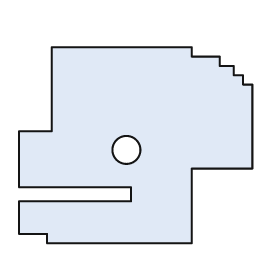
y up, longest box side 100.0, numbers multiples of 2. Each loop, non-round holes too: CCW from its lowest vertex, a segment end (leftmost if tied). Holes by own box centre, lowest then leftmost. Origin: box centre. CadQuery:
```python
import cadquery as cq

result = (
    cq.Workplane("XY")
    .moveTo(-38.0, -42.0)
    .lineTo(24.0, -42.0)
    .lineTo(24.0, -10.0)
    .lineTo(50.0, -10.0)
    .lineTo(50.0, 26.0)
    .lineTo(46.0, 26.0)
    .lineTo(46.0, 30.0)
    .lineTo(42.0, 30.0)
    .lineTo(42.0, 34.0)
    .lineTo(36.0, 34.0)
    .lineTo(36.0, 38.0)
    .lineTo(24.0, 38.0)
    .lineTo(24.0, 42.0)
    .lineTo(-36.0, 42.0)
    .lineTo(-36.0, 6.0)
    .lineTo(-50.0, 6.0)
    .lineTo(-50.0, -18.0)
    .lineTo(-2.0, -18.0)
    .lineTo(-2.0, -24.0)
    .lineTo(-50.0, -24.0)
    .lineTo(-50.0, -38.0)
    .lineTo(-38.0, -38.0)
    .close()
    .moveTo(-4.0, -2.0)
    .circle(6.0)
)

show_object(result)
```